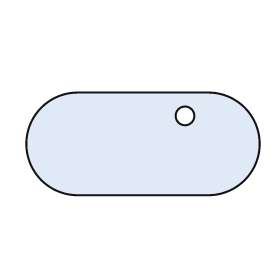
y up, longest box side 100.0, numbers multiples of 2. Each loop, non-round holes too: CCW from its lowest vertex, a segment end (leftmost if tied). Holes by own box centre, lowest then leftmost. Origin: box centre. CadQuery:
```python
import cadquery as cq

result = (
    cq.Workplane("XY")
    .moveTo(-28.0, -22.0)
    .lineTo(28.0, -22.0)
    .threePointArc((50.0, 0.0), (28.0, 22.0))
    .lineTo(-28.0, 22.0)
    .threePointArc((-50.0, 0.0), (-28.0, -22.0))
    .close()
    .moveTo(18.0, 12.0)
    .circle(4.0)
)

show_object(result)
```